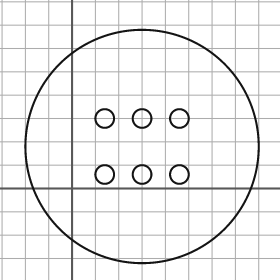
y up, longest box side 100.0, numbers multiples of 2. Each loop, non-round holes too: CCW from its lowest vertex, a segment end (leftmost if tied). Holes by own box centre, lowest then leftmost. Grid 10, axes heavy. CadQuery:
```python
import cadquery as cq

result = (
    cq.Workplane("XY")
    .moveTo(30.0, 18.0)
    .circle(50.0)
    .moveTo(14.0, 6.0)
    .circle(4.0)
    .moveTo(30.0, 6.0)
    .circle(4.0)
    .moveTo(46.0, 6.0)
    .circle(4.0)
    .moveTo(14.0, 30.0)
    .circle(4.0)
    .moveTo(30.0, 30.0)
    .circle(4.0)
    .moveTo(46.0, 30.0)
    .circle(4.0)
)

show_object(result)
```